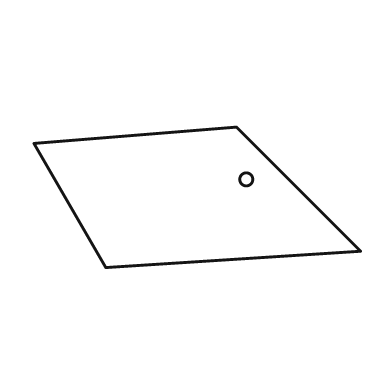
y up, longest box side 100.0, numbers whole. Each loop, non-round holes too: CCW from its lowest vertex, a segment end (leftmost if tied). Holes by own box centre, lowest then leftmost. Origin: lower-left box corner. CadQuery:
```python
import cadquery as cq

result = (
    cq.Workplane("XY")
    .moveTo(22.0, 0.0)
    .lineTo(100.0, 5.0)
    .lineTo(62.0, 43.0)
    .lineTo(0.0, 38.0)
    .close()
    .moveTo(65.0, 27.0)
    .circle(2.0)
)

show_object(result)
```